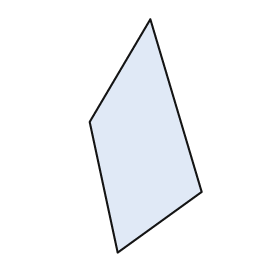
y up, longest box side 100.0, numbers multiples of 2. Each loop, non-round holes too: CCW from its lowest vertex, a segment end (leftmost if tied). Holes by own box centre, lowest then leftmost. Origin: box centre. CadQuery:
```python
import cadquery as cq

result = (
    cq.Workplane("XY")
    .moveTo(-12.0, -50.0)
    .lineTo(24.0, -24.0)
    .lineTo(2.0, 50.0)
    .lineTo(-24.0, 6.0)
    .close()
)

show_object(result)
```